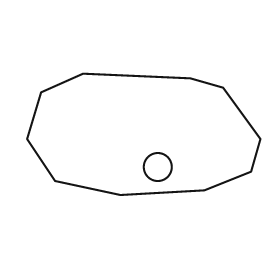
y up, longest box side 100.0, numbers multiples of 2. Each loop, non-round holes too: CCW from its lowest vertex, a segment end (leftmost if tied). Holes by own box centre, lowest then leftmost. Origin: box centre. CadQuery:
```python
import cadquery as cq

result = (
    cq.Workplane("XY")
    .moveTo(-10.0, -26.0)
    .lineTo(26.0, -24.0)
    .lineTo(46.0, -16.0)
    .lineTo(50.0, -2.0)
    .lineTo(34.0, 20.0)
    .lineTo(20.0, 24.0)
    .lineTo(-26.0, 26.0)
    .lineTo(-44.0, 18.0)
    .lineTo(-50.0, -2.0)
    .lineTo(-38.0, -20.0)
    .close()
    .moveTo(6.0, -14.0)
    .circle(6.0)
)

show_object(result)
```